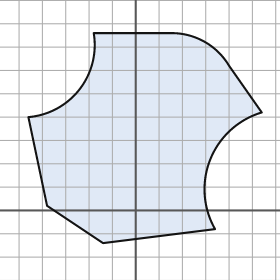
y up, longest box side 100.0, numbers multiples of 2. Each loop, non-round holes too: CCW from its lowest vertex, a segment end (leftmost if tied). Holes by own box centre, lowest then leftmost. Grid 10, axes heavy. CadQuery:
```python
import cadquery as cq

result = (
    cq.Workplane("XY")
    .moveTo(-14.0, -14.0)
    .lineTo(34.0, -8.0)
    .threePointArc((32.0, 22.0), (54.0, 42.0))
    .lineTo(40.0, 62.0)
    .threePointArc((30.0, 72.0), (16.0, 76.0))
    .lineTo(-18.0, 76.0)
    .threePointArc((-24.0, 52.0), (-46.0, 40.0))
    .lineTo(-38.0, 2.0)
    .close()
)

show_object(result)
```